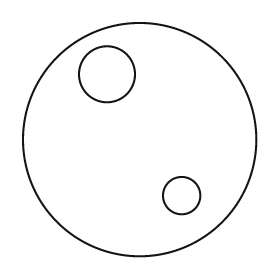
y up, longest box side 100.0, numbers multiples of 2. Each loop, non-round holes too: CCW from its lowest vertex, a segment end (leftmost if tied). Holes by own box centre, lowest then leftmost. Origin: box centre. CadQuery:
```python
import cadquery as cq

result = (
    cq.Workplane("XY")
    .moveTo(0.0, 0.0)
    .circle(50.0)
    .moveTo(18.0, -24.0)
    .circle(8.0)
    .moveTo(-14.0, 28.0)
    .circle(12.0)
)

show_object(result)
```